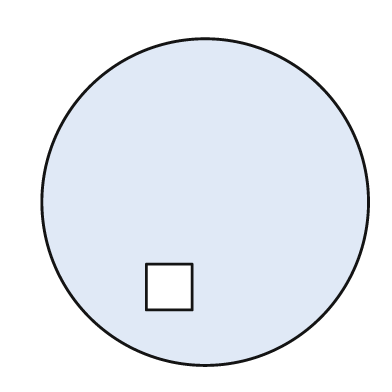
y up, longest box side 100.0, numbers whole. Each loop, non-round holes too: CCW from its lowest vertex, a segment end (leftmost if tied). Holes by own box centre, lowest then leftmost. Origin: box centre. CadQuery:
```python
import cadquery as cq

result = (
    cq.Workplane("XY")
    .moveTo(0.0, 0.0)
    .circle(50.0)
    .moveTo(-18.0, -33.0)
    .lineTo(-4.0, -33.0)
    .lineTo(-4.0, -19.0)
    .lineTo(-18.0, -19.0)
    .close()
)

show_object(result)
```